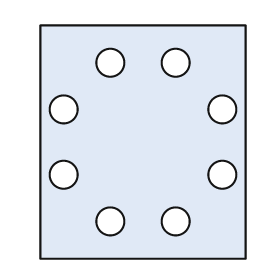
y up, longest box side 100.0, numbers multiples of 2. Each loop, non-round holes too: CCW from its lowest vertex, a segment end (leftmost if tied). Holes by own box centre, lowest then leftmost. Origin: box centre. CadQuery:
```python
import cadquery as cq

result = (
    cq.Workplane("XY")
    .moveTo(-44.0, -50.0)
    .lineTo(44.0, -50.0)
    .lineTo(44.0, 50.0)
    .lineTo(-44.0, 50.0)
    .close()
    .moveTo(-14.0, -34.0)
    .circle(6.0)
    .moveTo(14.0, -34.0)
    .circle(6.0)
    .moveTo(-34.0, -14.0)
    .circle(6.0)
    .moveTo(34.0, -14.0)
    .circle(6.0)
    .moveTo(-34.0, 14.0)
    .circle(6.0)
    .moveTo(34.0, 14.0)
    .circle(6.0)
    .moveTo(-14.0, 34.0)
    .circle(6.0)
    .moveTo(14.0, 34.0)
    .circle(6.0)
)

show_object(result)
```